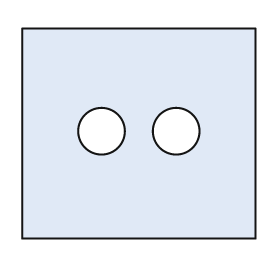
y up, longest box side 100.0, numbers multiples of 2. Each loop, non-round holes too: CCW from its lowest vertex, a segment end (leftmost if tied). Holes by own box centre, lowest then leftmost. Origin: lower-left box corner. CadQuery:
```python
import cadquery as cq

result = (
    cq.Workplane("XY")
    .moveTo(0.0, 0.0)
    .lineTo(100.0, 0.0)
    .lineTo(100.0, 90.0)
    .lineTo(0.0, 90.0)
    .close()
    .moveTo(34.0, 46.0)
    .circle(10.0)
    .moveTo(66.0, 46.0)
    .circle(10.0)
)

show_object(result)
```